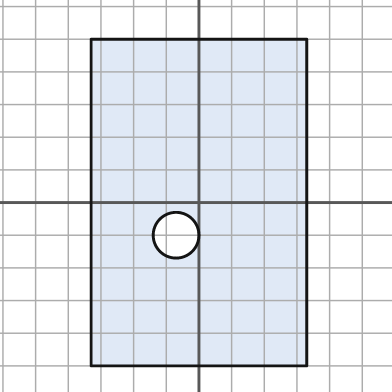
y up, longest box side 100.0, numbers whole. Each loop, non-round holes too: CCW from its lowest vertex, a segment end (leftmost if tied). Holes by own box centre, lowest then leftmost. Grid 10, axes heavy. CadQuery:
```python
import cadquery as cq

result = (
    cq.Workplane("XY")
    .moveTo(-33.0, -50.0)
    .lineTo(33.0, -50.0)
    .lineTo(33.0, 50.0)
    .lineTo(-33.0, 50.0)
    .close()
    .moveTo(-7.0, -10.0)
    .circle(7.0)
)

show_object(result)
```